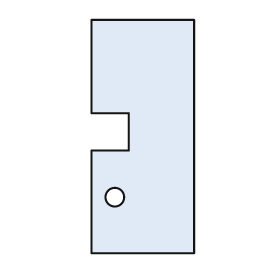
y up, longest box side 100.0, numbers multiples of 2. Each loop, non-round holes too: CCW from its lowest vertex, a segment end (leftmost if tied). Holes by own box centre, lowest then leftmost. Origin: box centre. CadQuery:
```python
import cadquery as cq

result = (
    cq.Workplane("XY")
    .moveTo(-22.0, -50.0)
    .lineTo(22.0, -50.0)
    .lineTo(22.0, 50.0)
    .lineTo(-22.0, 50.0)
    .lineTo(-22.0, 10.0)
    .lineTo(-6.0, 10.0)
    .lineTo(-6.0, -6.0)
    .lineTo(-22.0, -6.0)
    .close()
    .moveTo(-12.0, -26.0)
    .circle(4.0)
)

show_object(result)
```